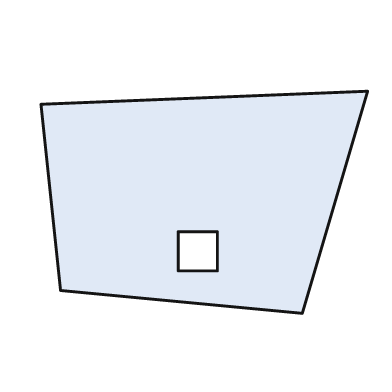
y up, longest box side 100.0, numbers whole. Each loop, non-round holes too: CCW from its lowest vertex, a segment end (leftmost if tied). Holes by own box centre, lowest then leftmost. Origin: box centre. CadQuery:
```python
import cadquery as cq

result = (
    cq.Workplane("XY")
    .moveTo(30.0, -34.0)
    .lineTo(50.0, 34.0)
    .lineTo(-50.0, 30.0)
    .lineTo(-44.0, -27.0)
    .close()
    .moveTo(-8.0, -21.0)
    .lineTo(4.0, -21.0)
    .lineTo(4.0, -9.0)
    .lineTo(-8.0, -9.0)
    .close()
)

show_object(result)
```